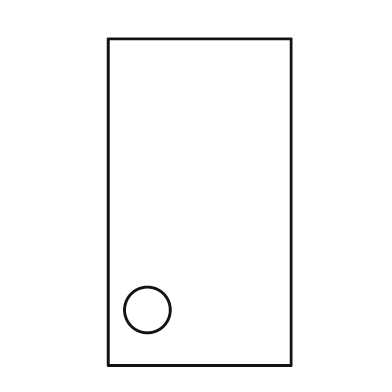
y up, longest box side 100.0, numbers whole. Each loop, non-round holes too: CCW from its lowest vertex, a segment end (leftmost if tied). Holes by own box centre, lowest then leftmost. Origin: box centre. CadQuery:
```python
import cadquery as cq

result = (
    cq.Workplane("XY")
    .moveTo(-28.0, -50.0)
    .lineTo(28.0, -50.0)
    .lineTo(28.0, 50.0)
    .lineTo(-28.0, 50.0)
    .close()
    .moveTo(-16.0, -33.0)
    .circle(7.0)
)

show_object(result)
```